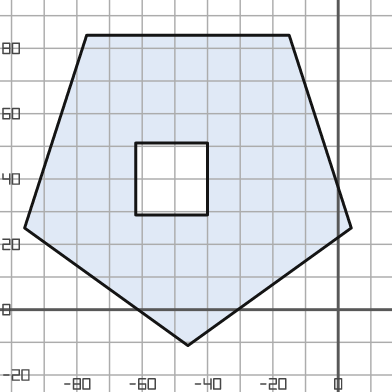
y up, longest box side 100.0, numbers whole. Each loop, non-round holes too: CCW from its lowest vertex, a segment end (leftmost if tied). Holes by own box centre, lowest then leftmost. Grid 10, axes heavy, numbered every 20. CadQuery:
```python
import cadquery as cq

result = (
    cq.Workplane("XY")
    .moveTo(-46.0, -11.0)
    .lineTo(4.0, 25.0)
    .lineTo(-15.0, 84.0)
    .lineTo(-77.0, 84.0)
    .lineTo(-96.0, 25.0)
    .close()
    .moveTo(-62.0, 29.0)
    .lineTo(-40.0, 29.0)
    .lineTo(-40.0, 51.0)
    .lineTo(-62.0, 51.0)
    .close()
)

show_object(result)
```